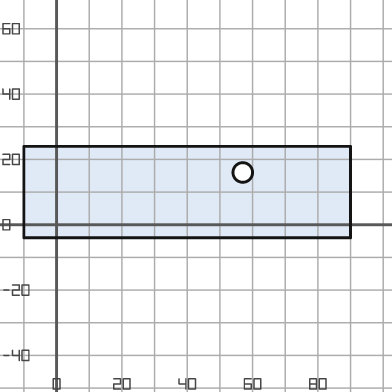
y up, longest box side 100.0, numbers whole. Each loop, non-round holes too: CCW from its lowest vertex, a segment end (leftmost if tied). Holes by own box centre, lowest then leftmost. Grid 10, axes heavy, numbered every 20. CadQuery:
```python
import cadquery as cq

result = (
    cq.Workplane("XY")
    .moveTo(-10.0, -4.0)
    .lineTo(90.0, -4.0)
    .lineTo(90.0, 24.0)
    .lineTo(-10.0, 24.0)
    .close()
    .moveTo(57.0, 16.0)
    .circle(3.0)
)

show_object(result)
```